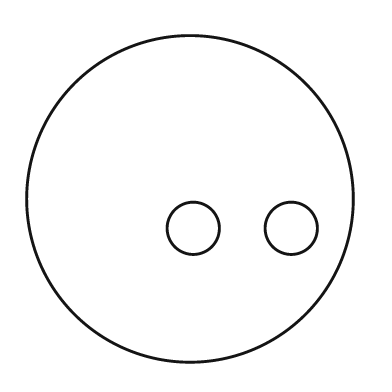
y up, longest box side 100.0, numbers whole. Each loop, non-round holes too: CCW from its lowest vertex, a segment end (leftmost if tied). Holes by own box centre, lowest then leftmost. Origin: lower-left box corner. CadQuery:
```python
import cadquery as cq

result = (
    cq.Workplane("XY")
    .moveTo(50.0, 50.0)
    .circle(50.0)
    .moveTo(51.0, 41.0)
    .circle(8.0)
    .moveTo(81.0, 41.0)
    .circle(8.0)
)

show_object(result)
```